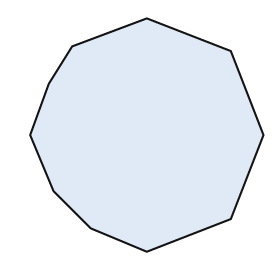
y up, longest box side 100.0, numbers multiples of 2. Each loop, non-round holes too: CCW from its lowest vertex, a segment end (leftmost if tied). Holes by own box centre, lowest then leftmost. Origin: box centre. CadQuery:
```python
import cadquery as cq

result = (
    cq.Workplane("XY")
    .moveTo(0.0, -50.0)
    .lineTo(36.0, -36.0)
    .lineTo(50.0, 0.0)
    .lineTo(36.0, 36.0)
    .lineTo(0.0, 50.0)
    .lineTo(-32.0, 38.0)
    .lineTo(-42.0, 22.0)
    .lineTo(-50.0, 0.0)
    .lineTo(-40.0, -24.0)
    .lineTo(-24.0, -40.0)
    .close()
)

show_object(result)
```